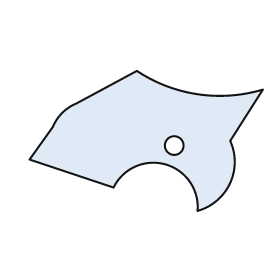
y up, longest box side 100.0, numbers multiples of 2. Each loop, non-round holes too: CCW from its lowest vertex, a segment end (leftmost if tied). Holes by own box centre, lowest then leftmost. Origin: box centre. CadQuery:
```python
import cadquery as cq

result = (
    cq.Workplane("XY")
    .moveTo(22.0, -30.0)
    .threePointArc((36.0, -18.0), (36.0, 0.0))
    .lineTo(50.0, 22.0)
    .threePointArc((22.0, 20.0), (-4.0, 30.0))
    .lineTo(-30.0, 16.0)
    .threePointArc((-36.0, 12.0), (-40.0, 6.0))
    .lineTo(-50.0, -8.0)
    .lineTo(-14.0, -20.0)
    .threePointArc((8.0, -10.0), (22.0, -30.0))
    .close()
    .moveTo(12.0, -2.0)
    .circle(4.0)
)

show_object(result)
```